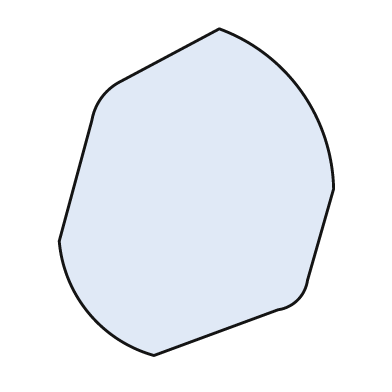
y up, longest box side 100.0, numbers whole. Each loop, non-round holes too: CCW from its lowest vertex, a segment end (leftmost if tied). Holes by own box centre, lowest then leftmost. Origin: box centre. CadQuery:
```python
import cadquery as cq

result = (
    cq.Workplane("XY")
    .moveTo(-13.0, -50.0)
    .lineTo(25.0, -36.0)
    .threePointArc((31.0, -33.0), (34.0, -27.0))
    .lineTo(42.0, 1.0)
    .threePointArc((32.0, 31.0), (7.0, 50.0))
    .lineTo(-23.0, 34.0)
    .threePointArc((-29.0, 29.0), (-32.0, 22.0))
    .lineTo(-42.0, -15.0)
    .threePointArc((-33.0, -37.0), (-13.0, -50.0))
    .close()
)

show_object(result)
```